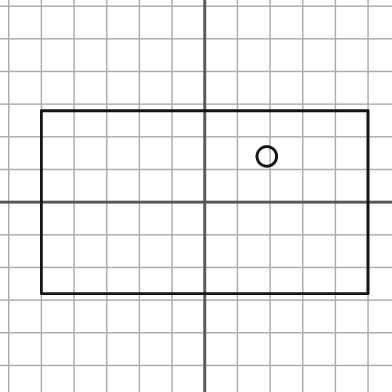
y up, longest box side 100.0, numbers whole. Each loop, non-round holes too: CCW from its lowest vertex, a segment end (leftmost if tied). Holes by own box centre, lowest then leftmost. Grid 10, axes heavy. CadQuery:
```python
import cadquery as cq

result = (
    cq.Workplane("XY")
    .moveTo(-50.0, -28.0)
    .lineTo(50.0, -28.0)
    .lineTo(50.0, 28.0)
    .lineTo(-50.0, 28.0)
    .close()
    .moveTo(19.0, 14.0)
    .circle(3.0)
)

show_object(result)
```